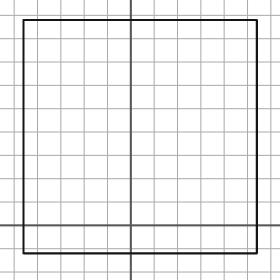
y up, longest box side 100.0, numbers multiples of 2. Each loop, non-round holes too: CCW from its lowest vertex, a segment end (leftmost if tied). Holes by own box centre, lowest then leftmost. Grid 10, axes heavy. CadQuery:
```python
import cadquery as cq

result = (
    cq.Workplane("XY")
    .moveTo(-46.0, -12.0)
    .lineTo(54.0, -12.0)
    .lineTo(54.0, 88.0)
    .lineTo(-46.0, 88.0)
    .close()
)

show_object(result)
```